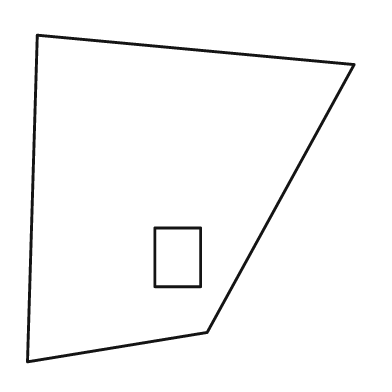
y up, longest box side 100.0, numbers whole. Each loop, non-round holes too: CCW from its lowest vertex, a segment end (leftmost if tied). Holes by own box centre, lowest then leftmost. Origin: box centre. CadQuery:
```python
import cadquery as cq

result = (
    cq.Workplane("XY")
    .moveTo(-50.0, -50.0)
    .lineTo(5.0, -41.0)
    .lineTo(50.0, 41.0)
    .lineTo(-47.0, 50.0)
    .close()
    .moveTo(-11.0, -27.0)
    .lineTo(3.0, -27.0)
    .lineTo(3.0, -9.0)
    .lineTo(-11.0, -9.0)
    .close()
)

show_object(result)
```